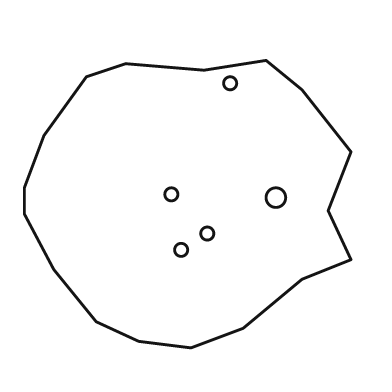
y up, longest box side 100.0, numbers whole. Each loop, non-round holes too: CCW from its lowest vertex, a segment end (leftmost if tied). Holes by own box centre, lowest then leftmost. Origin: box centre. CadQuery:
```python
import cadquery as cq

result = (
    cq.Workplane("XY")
    .moveTo(1.0, -44.0)
    .lineTo(17.0, -38.0)
    .lineTo(35.0, -23.0)
    .lineTo(50.0, -17.0)
    .lineTo(43.0, -2.0)
    .lineTo(50.0, 16.0)
    .lineTo(35.0, 35.0)
    .lineTo(24.0, 44.0)
    .lineTo(5.0, 41.0)
    .lineTo(-19.0, 43.0)
    .lineTo(-31.0, 39.0)
    .lineTo(-44.0, 21.0)
    .lineTo(-50.0, 5.0)
    .lineTo(-50.0, -3.0)
    .lineTo(-41.0, -20.0)
    .lineTo(-28.0, -36.0)
    .lineTo(-15.0, -42.0)
    .close()
    .moveTo(-2.0, -14.0)
    .circle(2.0)
    .moveTo(6.0, -9.0)
    .circle(2.0)
    .moveTo(27.0, 2.0)
    .circle(3.0)
    .moveTo(-5.0, 3.0)
    .circle(2.0)
    .moveTo(13.0, 37.0)
    .circle(2.0)
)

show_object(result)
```